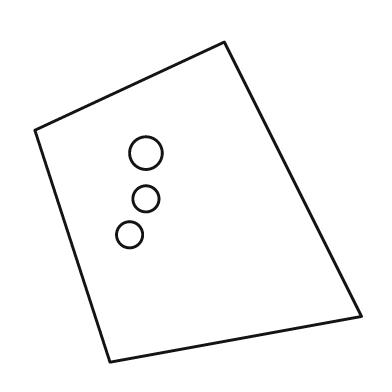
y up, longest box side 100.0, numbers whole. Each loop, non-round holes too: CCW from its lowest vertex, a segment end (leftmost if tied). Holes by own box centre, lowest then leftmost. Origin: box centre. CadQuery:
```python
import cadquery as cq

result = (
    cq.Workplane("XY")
    .moveTo(-27.0, -49.0)
    .lineTo(50.0, -35.0)
    .lineTo(8.0, 49.0)
    .lineTo(-50.0, 22.0)
    .close()
    .moveTo(-21.0, -10.0)
    .circle(4.0)
    .moveTo(-16.0, 1.0)
    .circle(4.0)
    .moveTo(-16.0, 15.0)
    .circle(5.0)
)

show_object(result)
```